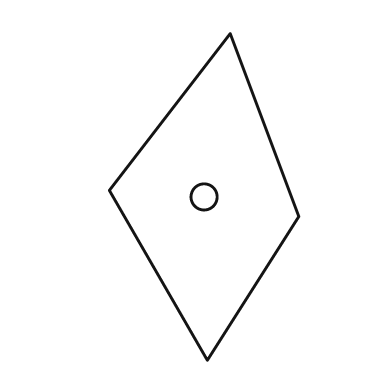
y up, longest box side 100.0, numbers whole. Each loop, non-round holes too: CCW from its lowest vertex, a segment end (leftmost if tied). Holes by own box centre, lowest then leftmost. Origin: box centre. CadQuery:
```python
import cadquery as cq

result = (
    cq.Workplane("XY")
    .moveTo(1.0, -50.0)
    .lineTo(29.0, -6.0)
    .lineTo(8.0, 50.0)
    .lineTo(-29.0, 2.0)
    .close()
    .moveTo(0.0, 0.0)
    .circle(4.0)
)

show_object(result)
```